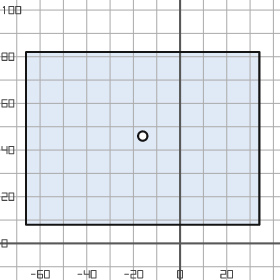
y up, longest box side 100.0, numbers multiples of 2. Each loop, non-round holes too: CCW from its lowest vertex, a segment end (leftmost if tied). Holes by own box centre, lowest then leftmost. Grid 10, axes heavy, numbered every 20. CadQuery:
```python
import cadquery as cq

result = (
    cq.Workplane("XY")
    .moveTo(-66.0, 8.0)
    .lineTo(34.0, 8.0)
    .lineTo(34.0, 82.0)
    .lineTo(-66.0, 82.0)
    .close()
    .moveTo(-16.0, 46.0)
    .circle(2.0)
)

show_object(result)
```